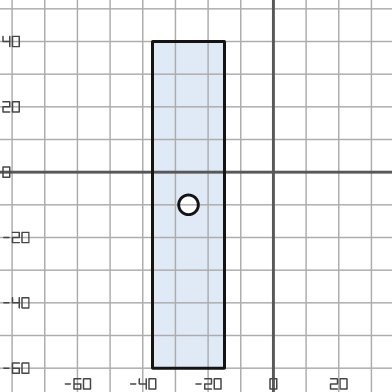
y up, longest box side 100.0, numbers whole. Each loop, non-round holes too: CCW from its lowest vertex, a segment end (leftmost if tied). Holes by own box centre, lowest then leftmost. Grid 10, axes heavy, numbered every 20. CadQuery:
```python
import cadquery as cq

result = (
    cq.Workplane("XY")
    .moveTo(-37.0, -60.0)
    .lineTo(-15.0, -60.0)
    .lineTo(-15.0, 40.0)
    .lineTo(-37.0, 40.0)
    .close()
    .moveTo(-26.0, -10.0)
    .circle(3.0)
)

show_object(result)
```